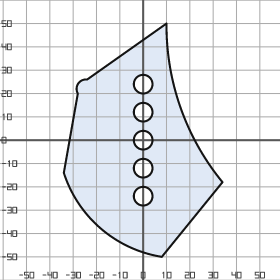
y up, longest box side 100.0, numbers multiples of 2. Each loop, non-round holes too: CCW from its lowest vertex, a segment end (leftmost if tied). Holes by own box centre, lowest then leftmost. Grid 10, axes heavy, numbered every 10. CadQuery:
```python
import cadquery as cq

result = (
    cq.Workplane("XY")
    .moveTo(8.0, -50.0)
    .lineTo(34.0, -18.0)
    .threePointArc((16.0, 14.0), (10.0, 50.0))
    .lineTo(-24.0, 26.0)
    .threePointArc((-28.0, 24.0), (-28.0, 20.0))
    .lineTo(-34.0, -14.0)
    .threePointArc((-18.0, -38.0), (8.0, -50.0))
    .close()
    .moveTo(0.0, -24.0)
    .circle(4.0)
    .moveTo(0.0, -12.0)
    .circle(4.0)
    .moveTo(0.0, 0.0)
    .circle(4.0)
    .moveTo(0.0, 12.0)
    .circle(4.0)
    .moveTo(0.0, 24.0)
    .circle(4.0)
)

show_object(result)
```